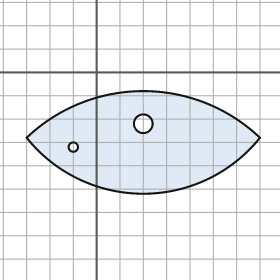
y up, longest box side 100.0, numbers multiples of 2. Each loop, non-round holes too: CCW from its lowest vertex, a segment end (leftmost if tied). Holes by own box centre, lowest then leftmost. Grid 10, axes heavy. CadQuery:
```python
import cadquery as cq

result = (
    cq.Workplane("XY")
    .moveTo(-30.0, -28.0)
    .threePointArc((20.0, -52.0), (70.0, -28.0))
    .threePointArc((20.0, -8.0), (-30.0, -28.0))
    .close()
    .moveTo(-10.0, -32.0)
    .circle(2.0)
    .moveTo(20.0, -22.0)
    .circle(4.0)
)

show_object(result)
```